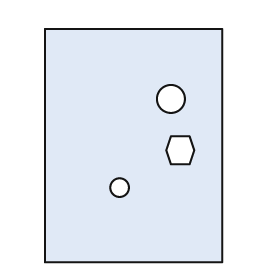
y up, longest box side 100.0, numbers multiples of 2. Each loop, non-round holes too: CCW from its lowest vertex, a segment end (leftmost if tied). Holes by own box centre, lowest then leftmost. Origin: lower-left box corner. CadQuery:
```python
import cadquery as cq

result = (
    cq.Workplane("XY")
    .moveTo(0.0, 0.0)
    .lineTo(76.0, 0.0)
    .lineTo(76.0, 100.0)
    .lineTo(0.0, 100.0)
    .close()
    .moveTo(32.0, 32.0)
    .circle(4.0)
    .moveTo(54.0, 42.0)
    .lineTo(62.0, 42.0)
    .lineTo(64.0, 48.0)
    .lineTo(62.0, 54.0)
    .lineTo(54.0, 54.0)
    .lineTo(52.0, 48.0)
    .close()
    .moveTo(54.0, 70.0)
    .circle(6.0)
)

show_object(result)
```